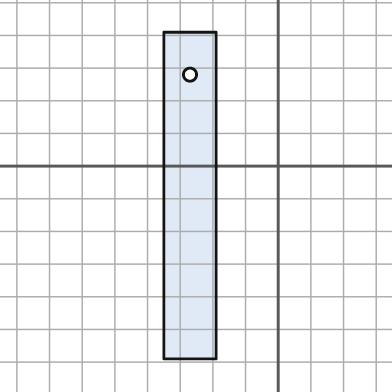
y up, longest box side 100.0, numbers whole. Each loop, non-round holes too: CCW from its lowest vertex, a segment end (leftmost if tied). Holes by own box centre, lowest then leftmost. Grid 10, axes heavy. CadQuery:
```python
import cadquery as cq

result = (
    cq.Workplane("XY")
    .moveTo(-35.0, -59.0)
    .lineTo(-19.0, -59.0)
    .lineTo(-19.0, 41.0)
    .lineTo(-35.0, 41.0)
    .close()
    .moveTo(-27.0, 28.0)
    .circle(2.0)
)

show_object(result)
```